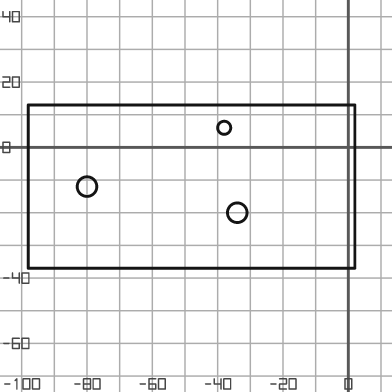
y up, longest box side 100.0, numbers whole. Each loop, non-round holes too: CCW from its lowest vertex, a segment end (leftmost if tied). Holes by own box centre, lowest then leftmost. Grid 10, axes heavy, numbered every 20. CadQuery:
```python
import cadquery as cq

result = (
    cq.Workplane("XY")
    .moveTo(-98.0, -37.0)
    .lineTo(2.0, -37.0)
    .lineTo(2.0, 13.0)
    .lineTo(-98.0, 13.0)
    .close()
    .moveTo(-34.0, -20.0)
    .circle(3.0)
    .moveTo(-80.0, -12.0)
    .circle(3.0)
    .moveTo(-38.0, 6.0)
    .circle(2.0)
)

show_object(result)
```